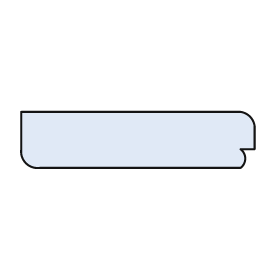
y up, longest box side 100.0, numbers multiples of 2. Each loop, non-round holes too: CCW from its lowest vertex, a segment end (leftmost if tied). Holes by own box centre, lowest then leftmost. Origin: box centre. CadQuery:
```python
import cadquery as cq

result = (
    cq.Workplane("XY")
    .moveTo(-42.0, -12.0)
    .lineTo(44.0, -12.0)
    .threePointArc((46.0, -8.0), (44.0, -4.0))
    .lineTo(50.0, -4.0)
    .lineTo(50.0, 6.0)
    .threePointArc((48.0, 10.0), (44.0, 12.0))
    .lineTo(-50.0, 12.0)
    .lineTo(-50.0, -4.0)
    .threePointArc((-48.0, -10.0), (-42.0, -12.0))
    .close()
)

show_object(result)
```